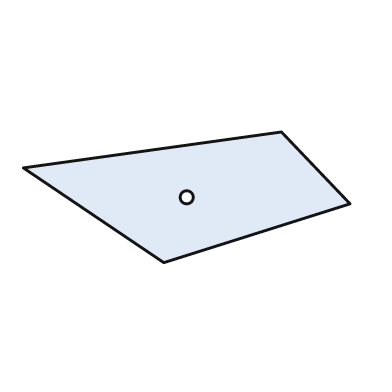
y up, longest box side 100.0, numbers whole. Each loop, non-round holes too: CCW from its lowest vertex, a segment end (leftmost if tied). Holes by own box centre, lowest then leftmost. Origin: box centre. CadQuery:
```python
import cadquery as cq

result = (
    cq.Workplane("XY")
    .moveTo(-7.0, -20.0)
    .lineTo(50.0, -2.0)
    .lineTo(29.0, 20.0)
    .lineTo(-50.0, 9.0)
    .close()
    .moveTo(0.0, 0.0)
    .circle(2.0)
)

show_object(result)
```